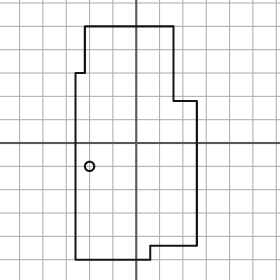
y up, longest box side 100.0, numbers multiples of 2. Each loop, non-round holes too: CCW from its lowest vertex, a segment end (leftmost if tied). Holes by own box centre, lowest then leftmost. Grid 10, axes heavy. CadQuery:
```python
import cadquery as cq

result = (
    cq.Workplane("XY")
    .moveTo(-26.0, -50.0)
    .lineTo(6.0, -50.0)
    .lineTo(6.0, -44.0)
    .lineTo(26.0, -44.0)
    .lineTo(26.0, 18.0)
    .lineTo(16.0, 18.0)
    .lineTo(16.0, 50.0)
    .lineTo(-22.0, 50.0)
    .lineTo(-22.0, 30.0)
    .lineTo(-26.0, 30.0)
    .close()
    .moveTo(-20.0, -10.0)
    .circle(2.0)
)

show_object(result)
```